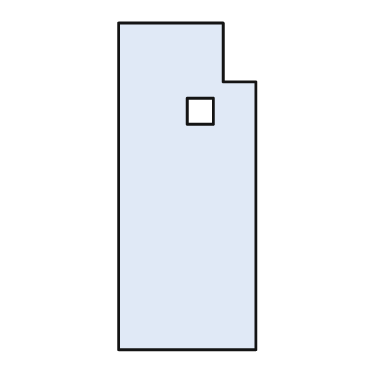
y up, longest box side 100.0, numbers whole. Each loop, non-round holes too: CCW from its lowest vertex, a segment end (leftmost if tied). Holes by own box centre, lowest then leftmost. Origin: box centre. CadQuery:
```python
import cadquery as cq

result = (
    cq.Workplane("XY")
    .moveTo(-21.0, -50.0)
    .lineTo(21.0, -50.0)
    .lineTo(21.0, 32.0)
    .lineTo(11.0, 32.0)
    .lineTo(11.0, 50.0)
    .lineTo(-21.0, 50.0)
    .close()
    .moveTo(0.0, 19.0)
    .lineTo(8.0, 19.0)
    .lineTo(8.0, 27.0)
    .lineTo(0.0, 27.0)
    .close()
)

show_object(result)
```